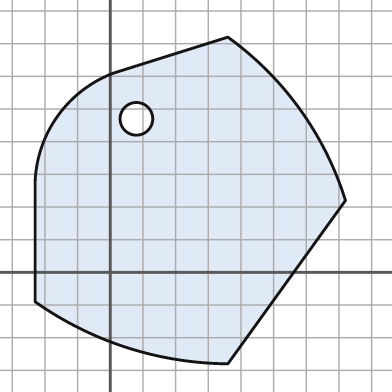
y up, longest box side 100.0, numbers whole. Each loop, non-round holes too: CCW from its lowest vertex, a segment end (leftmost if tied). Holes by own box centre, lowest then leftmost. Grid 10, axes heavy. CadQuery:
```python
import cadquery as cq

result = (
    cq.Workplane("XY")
    .moveTo(36.0, -28.0)
    .lineTo(72.0, 22.0)
    .threePointArc((58.0, 50.0), (36.0, 72.0))
    .lineTo(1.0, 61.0)
    .threePointArc((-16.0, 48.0), (-23.0, 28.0))
    .lineTo(-23.0, -9.0)
    .threePointArc((5.0, -23.0), (36.0, -28.0))
    .close()
    .moveTo(8.0, 47.0)
    .circle(5.0)
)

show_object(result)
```